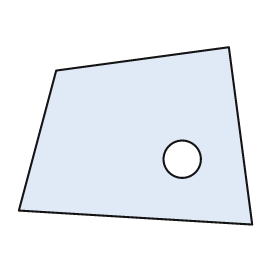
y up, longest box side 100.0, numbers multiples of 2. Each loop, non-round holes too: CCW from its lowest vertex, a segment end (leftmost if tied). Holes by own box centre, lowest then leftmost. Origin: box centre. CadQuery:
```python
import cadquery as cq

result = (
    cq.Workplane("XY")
    .moveTo(50.0, -38.0)
    .lineTo(40.0, 38.0)
    .lineTo(-34.0, 28.0)
    .lineTo(-50.0, -32.0)
    .close()
    .moveTo(20.0, -10.0)
    .circle(8.0)
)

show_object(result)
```